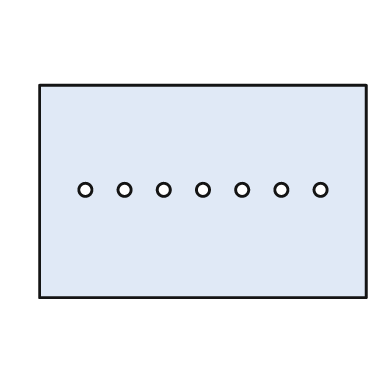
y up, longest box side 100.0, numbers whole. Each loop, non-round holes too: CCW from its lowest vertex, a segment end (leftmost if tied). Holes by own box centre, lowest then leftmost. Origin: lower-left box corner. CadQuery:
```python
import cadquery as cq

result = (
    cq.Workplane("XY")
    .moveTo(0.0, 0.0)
    .lineTo(100.0, 0.0)
    .lineTo(100.0, 65.0)
    .lineTo(0.0, 65.0)
    .close()
    .moveTo(14.0, 33.0)
    .circle(2.0)
    .moveTo(26.0, 33.0)
    .circle(2.0)
    .moveTo(38.0, 33.0)
    .circle(2.0)
    .moveTo(50.0, 33.0)
    .circle(2.0)
    .moveTo(62.0, 33.0)
    .circle(2.0)
    .moveTo(74.0, 33.0)
    .circle(2.0)
    .moveTo(86.0, 33.0)
    .circle(2.0)
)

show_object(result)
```